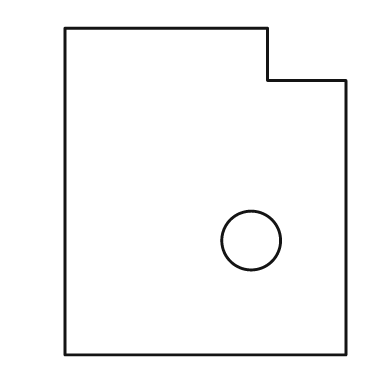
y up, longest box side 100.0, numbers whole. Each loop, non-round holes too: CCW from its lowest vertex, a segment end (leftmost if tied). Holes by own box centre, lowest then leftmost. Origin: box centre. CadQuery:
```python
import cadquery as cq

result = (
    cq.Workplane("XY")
    .moveTo(-43.0, -50.0)
    .lineTo(43.0, -50.0)
    .lineTo(43.0, 34.0)
    .lineTo(19.0, 34.0)
    .lineTo(19.0, 50.0)
    .lineTo(-43.0, 50.0)
    .close()
    .moveTo(14.0, -15.0)
    .circle(9.0)
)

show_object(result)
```